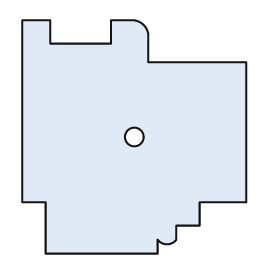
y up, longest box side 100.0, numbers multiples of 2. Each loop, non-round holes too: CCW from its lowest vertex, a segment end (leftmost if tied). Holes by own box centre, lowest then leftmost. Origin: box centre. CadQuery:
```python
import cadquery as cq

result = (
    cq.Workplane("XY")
    .moveTo(-38.0, -50.0)
    .lineTo(10.0, -50.0)
    .lineTo(10.0, -44.0)
    .threePointArc((14.0, -46.0), (18.0, -44.0))
    .lineTo(18.0, -38.0)
    .lineTo(28.0, -38.0)
    .lineTo(28.0, -28.0)
    .lineTo(48.0, -28.0)
    .lineTo(48.0, 32.0)
    .lineTo(6.0, 32.0)
    .lineTo(6.0, 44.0)
    .threePointArc((4.0, 48.0), (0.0, 50.0))
    .lineTo(-10.0, 50.0)
    .lineTo(-10.0, 40.0)
    .lineTo(-36.0, 40.0)
    .lineTo(-36.0, 50.0)
    .lineTo(-48.0, 50.0)
    .lineTo(-48.0, -28.0)
    .lineTo(-38.0, -28.0)
    .close()
    .moveTo(0.0, 0.0)
    .circle(4.0)
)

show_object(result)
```